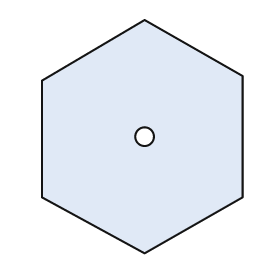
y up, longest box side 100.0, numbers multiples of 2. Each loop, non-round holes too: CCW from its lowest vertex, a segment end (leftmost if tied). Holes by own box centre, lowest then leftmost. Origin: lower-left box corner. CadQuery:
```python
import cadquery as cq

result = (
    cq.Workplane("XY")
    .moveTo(44.0, 0.0)
    .lineTo(86.0, 24.0)
    .lineTo(86.0, 76.0)
    .lineTo(44.0, 100.0)
    .lineTo(0.0, 74.0)
    .lineTo(0.0, 24.0)
    .close()
    .moveTo(44.0, 50.0)
    .circle(4.0)
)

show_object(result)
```